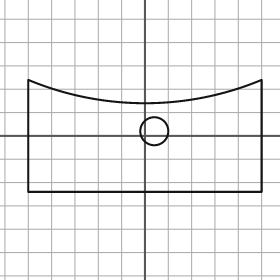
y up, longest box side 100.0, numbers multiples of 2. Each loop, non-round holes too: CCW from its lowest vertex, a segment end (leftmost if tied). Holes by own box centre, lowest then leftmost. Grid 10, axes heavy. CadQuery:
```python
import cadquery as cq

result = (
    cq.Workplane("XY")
    .moveTo(-50.0, -24.0)
    .lineTo(50.0, -24.0)
    .lineTo(50.0, 24.0)
    .threePointArc((0.0, 14.0), (-50.0, 24.0))
    .close()
    .moveTo(4.0, 2.0)
    .circle(6.0)
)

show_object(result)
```